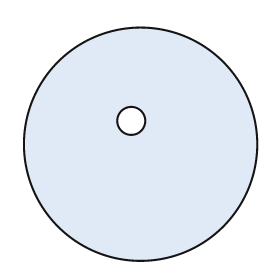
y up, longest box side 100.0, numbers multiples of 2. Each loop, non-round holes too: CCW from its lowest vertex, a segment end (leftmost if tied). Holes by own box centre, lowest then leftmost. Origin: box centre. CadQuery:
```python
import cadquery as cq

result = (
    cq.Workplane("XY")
    .moveTo(0.0, 0.0)
    .circle(50.0)
    .moveTo(-4.0, 10.0)
    .circle(6.0)
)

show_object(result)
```